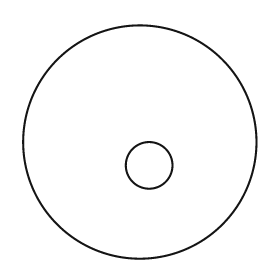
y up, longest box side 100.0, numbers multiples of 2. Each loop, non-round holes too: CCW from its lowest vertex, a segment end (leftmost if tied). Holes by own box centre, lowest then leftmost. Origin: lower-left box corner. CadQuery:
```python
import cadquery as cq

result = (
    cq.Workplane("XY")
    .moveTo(50.0, 50.0)
    .circle(50.0)
    .moveTo(54.0, 40.0)
    .circle(10.0)
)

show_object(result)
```